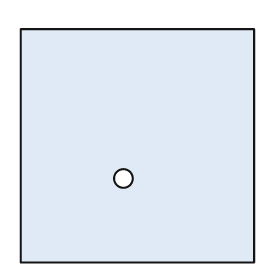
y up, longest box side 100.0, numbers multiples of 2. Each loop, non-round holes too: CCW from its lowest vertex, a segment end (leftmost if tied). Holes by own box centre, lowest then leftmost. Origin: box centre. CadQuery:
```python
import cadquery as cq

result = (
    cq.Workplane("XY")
    .moveTo(-50.0, -50.0)
    .lineTo(50.0, -50.0)
    .lineTo(50.0, 50.0)
    .lineTo(-50.0, 50.0)
    .close()
    .moveTo(-6.0, -14.0)
    .circle(4.0)
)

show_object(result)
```